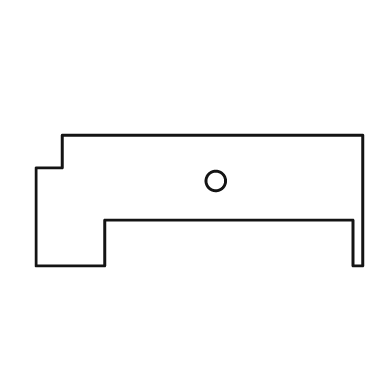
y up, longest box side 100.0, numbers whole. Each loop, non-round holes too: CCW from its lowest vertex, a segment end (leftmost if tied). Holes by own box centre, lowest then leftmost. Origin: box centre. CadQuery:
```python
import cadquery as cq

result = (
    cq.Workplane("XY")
    .moveTo(-50.0, -20.0)
    .lineTo(-29.0, -20.0)
    .lineTo(-29.0, -6.0)
    .lineTo(47.0, -6.0)
    .lineTo(47.0, -20.0)
    .lineTo(50.0, -20.0)
    .lineTo(50.0, 20.0)
    .lineTo(-42.0, 20.0)
    .lineTo(-42.0, 10.0)
    .lineTo(-50.0, 10.0)
    .close()
    .moveTo(5.0, 6.0)
    .circle(3.0)
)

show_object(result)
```